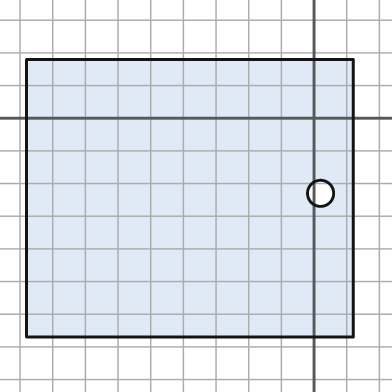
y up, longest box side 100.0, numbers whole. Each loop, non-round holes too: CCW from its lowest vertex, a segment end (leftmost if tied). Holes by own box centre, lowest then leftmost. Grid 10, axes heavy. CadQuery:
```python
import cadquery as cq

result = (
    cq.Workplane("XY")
    .moveTo(-88.0, -67.0)
    .lineTo(12.0, -67.0)
    .lineTo(12.0, 18.0)
    .lineTo(-88.0, 18.0)
    .close()
    .moveTo(2.0, -23.0)
    .circle(4.0)
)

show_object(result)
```